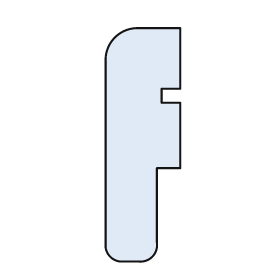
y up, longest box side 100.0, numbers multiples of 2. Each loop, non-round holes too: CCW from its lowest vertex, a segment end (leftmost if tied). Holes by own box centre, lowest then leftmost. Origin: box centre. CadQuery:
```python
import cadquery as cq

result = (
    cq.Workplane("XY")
    .moveTo(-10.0, -50.0)
    .lineTo(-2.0, -50.0)
    .threePointArc((4.0, -48.0), (6.0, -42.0))
    .lineTo(6.0, -10.0)
    .lineTo(16.0, -10.0)
    .lineTo(16.0, 18.0)
    .lineTo(8.0, 18.0)
    .lineTo(8.0, 24.0)
    .lineTo(16.0, 24.0)
    .lineTo(16.0, 50.0)
    .lineTo(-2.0, 50.0)
    .threePointArc((-12.0, 46.0), (-16.0, 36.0))
    .lineTo(-16.0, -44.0)
    .threePointArc((-14.0, -48.0), (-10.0, -50.0))
    .close()
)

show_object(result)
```